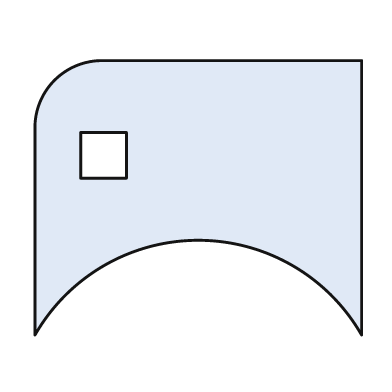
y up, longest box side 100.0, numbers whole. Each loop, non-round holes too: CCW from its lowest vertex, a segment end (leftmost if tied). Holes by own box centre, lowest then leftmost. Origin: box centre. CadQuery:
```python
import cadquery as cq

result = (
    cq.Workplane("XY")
    .moveTo(-50.0, -42.0)
    .threePointArc((0.0, -13.0), (50.0, -42.0))
    .lineTo(50.0, 42.0)
    .lineTo(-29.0, 42.0)
    .threePointArc((-44.0, 36.0), (-50.0, 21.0))
    .close()
    .moveTo(-36.0, 6.0)
    .lineTo(-22.0, 6.0)
    .lineTo(-22.0, 20.0)
    .lineTo(-36.0, 20.0)
    .close()
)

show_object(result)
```